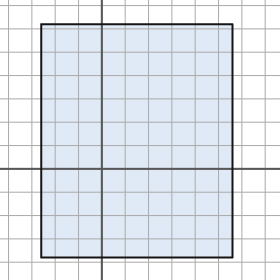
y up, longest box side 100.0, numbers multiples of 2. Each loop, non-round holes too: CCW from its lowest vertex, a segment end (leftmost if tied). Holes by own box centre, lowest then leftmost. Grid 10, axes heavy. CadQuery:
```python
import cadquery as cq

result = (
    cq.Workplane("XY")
    .moveTo(-26.0, -38.0)
    .lineTo(56.0, -38.0)
    .lineTo(56.0, 62.0)
    .lineTo(-26.0, 62.0)
    .close()
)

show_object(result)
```